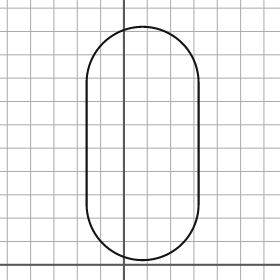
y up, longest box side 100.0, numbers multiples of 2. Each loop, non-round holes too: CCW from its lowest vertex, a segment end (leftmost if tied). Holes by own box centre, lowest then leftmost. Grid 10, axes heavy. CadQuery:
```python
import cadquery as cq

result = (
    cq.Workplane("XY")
    .moveTo(-16.0, 26.0)
    .threePointArc((8.0, 2.0), (32.0, 26.0))
    .lineTo(32.0, 78.0)
    .threePointArc((8.0, 102.0), (-16.0, 78.0))
    .close()
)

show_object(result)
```